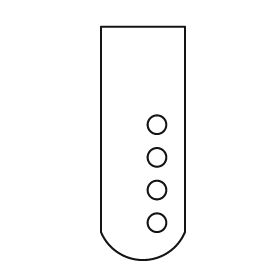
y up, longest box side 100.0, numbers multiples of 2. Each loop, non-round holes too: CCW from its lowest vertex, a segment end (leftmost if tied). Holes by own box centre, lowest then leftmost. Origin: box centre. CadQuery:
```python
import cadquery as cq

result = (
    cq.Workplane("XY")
    .moveTo(-18.0, -38.0)
    .threePointArc((0.0, -50.0), (18.0, -38.0))
    .lineTo(18.0, 50.0)
    .lineTo(-18.0, 50.0)
    .close()
    .moveTo(6.0, -34.0)
    .circle(4.0)
    .moveTo(6.0, -20.0)
    .circle(4.0)
    .moveTo(6.0, -6.0)
    .circle(4.0)
    .moveTo(6.0, 8.0)
    .circle(4.0)
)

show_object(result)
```